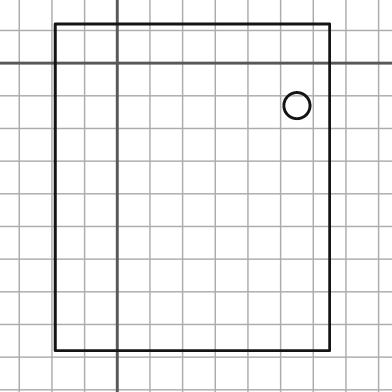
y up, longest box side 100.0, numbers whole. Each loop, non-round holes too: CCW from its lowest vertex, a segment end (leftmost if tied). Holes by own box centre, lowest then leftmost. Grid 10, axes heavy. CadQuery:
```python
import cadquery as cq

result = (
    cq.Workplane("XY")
    .moveTo(-19.0, -88.0)
    .lineTo(65.0, -88.0)
    .lineTo(65.0, 12.0)
    .lineTo(-19.0, 12.0)
    .close()
    .moveTo(55.0, -13.0)
    .circle(4.0)
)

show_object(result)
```